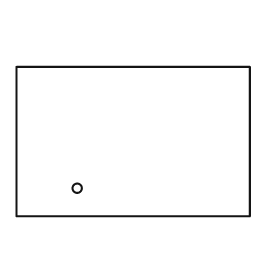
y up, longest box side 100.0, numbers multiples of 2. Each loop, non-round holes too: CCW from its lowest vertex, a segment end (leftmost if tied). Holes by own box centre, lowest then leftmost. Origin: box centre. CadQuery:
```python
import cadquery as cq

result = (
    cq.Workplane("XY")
    .moveTo(-50.0, -32.0)
    .lineTo(50.0, -32.0)
    .lineTo(50.0, 32.0)
    .lineTo(-50.0, 32.0)
    .close()
    .moveTo(-24.0, -20.0)
    .circle(2.0)
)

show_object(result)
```